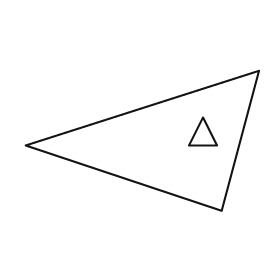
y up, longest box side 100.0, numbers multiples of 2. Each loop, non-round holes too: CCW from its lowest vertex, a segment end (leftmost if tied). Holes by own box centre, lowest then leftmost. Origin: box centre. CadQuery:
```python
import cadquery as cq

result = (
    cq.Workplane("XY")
    .moveTo(34.0, -30.0)
    .lineTo(50.0, 30.0)
    .lineTo(-50.0, -2.0)
    .close()
    .moveTo(20.0, -2.0)
    .lineTo(32.0, -2.0)
    .lineTo(26.0, 10.0)
    .close()
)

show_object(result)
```